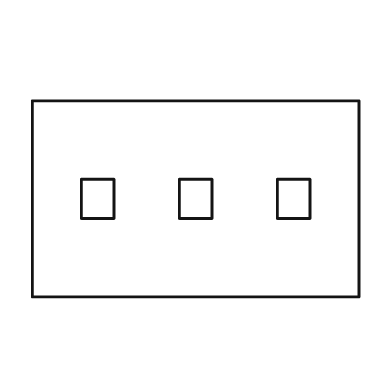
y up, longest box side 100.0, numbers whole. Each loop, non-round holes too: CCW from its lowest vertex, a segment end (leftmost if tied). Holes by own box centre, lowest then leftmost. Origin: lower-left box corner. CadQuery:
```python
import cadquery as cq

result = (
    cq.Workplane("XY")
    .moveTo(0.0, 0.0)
    .lineTo(100.0, 0.0)
    .lineTo(100.0, 60.0)
    .lineTo(0.0, 60.0)
    .close()
    .moveTo(15.0, 24.0)
    .lineTo(25.0, 24.0)
    .lineTo(25.0, 36.0)
    .lineTo(15.0, 36.0)
    .close()
    .moveTo(45.0, 24.0)
    .lineTo(55.0, 24.0)
    .lineTo(55.0, 36.0)
    .lineTo(45.0, 36.0)
    .close()
    .moveTo(75.0, 24.0)
    .lineTo(85.0, 24.0)
    .lineTo(85.0, 36.0)
    .lineTo(75.0, 36.0)
    .close()
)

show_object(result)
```